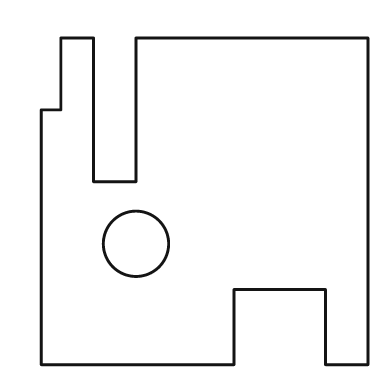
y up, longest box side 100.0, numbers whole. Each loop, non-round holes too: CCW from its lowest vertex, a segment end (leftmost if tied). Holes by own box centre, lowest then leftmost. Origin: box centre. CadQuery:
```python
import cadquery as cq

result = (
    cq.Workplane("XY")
    .moveTo(-50.0, -50.0)
    .lineTo(9.0, -50.0)
    .lineTo(9.0, -27.0)
    .lineTo(37.0, -27.0)
    .lineTo(37.0, -50.0)
    .lineTo(50.0, -50.0)
    .lineTo(50.0, 50.0)
    .lineTo(-21.0, 50.0)
    .lineTo(-21.0, 6.0)
    .lineTo(-34.0, 6.0)
    .lineTo(-34.0, 50.0)
    .lineTo(-44.0, 50.0)
    .lineTo(-44.0, 28.0)
    .lineTo(-50.0, 28.0)
    .close()
    .moveTo(-21.0, -13.0)
    .circle(10.0)
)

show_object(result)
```